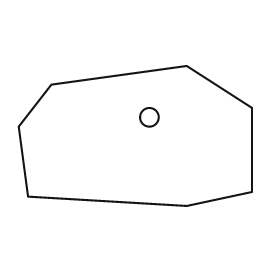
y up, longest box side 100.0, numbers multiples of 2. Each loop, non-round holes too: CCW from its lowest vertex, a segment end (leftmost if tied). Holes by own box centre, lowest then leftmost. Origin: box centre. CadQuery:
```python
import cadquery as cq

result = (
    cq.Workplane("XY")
    .moveTo(22.0, -30.0)
    .lineTo(50.0, -24.0)
    .lineTo(50.0, 12.0)
    .lineTo(22.0, 30.0)
    .lineTo(-36.0, 22.0)
    .lineTo(-50.0, 4.0)
    .lineTo(-46.0, -26.0)
    .close()
    .moveTo(6.0, 8.0)
    .circle(4.0)
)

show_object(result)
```